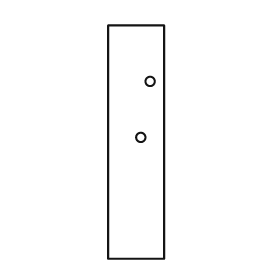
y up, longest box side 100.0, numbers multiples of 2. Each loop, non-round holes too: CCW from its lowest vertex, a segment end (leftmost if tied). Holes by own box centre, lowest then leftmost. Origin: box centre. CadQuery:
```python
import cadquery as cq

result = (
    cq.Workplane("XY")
    .moveTo(-12.0, -50.0)
    .lineTo(12.0, -50.0)
    .lineTo(12.0, 50.0)
    .lineTo(-12.0, 50.0)
    .close()
    .moveTo(2.0, 2.0)
    .circle(2.0)
    .moveTo(6.0, 26.0)
    .circle(2.0)
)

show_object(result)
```